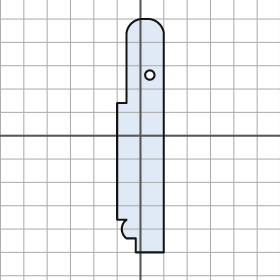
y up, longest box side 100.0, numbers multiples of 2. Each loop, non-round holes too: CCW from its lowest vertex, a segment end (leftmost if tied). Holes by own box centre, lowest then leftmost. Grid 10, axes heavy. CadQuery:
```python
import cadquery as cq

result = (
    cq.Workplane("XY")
    .moveTo(-2.0, -50.0)
    .lineTo(10.0, -50.0)
    .lineTo(10.0, 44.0)
    .threePointArc((8.0, 48.0), (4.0, 50.0))
    .lineTo(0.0, 50.0)
    .threePointArc((-4.0, 48.0), (-6.0, 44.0))
    .lineTo(-6.0, 14.0)
    .lineTo(-10.0, 14.0)
    .lineTo(-10.0, -36.0)
    .lineTo(-6.0, -36.0)
    .threePointArc((-8.0, -40.0), (-6.0, -44.0))
    .lineTo(-2.0, -44.0)
    .close()
    .moveTo(4.0, 26.0)
    .circle(2.0)
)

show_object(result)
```